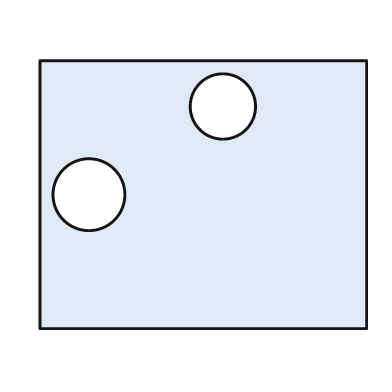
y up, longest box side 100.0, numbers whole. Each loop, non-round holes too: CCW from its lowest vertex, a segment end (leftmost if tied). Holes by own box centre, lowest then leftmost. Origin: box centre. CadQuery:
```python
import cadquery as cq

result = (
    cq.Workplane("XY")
    .moveTo(-50.0, -41.0)
    .lineTo(50.0, -41.0)
    .lineTo(50.0, 41.0)
    .lineTo(-50.0, 41.0)
    .close()
    .moveTo(-35.0, 0.0)
    .circle(11.0)
    .moveTo(6.0, 27.0)
    .circle(10.0)
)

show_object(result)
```